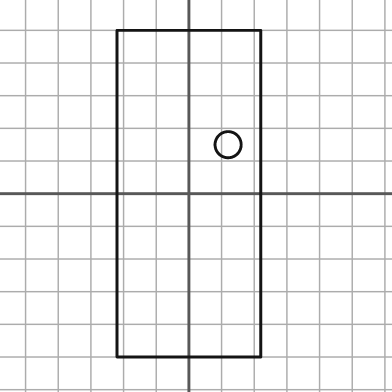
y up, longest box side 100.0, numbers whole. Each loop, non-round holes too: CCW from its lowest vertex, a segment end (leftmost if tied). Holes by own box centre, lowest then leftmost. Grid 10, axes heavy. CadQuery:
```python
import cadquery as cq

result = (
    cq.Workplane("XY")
    .moveTo(-22.0, -50.0)
    .lineTo(22.0, -50.0)
    .lineTo(22.0, 50.0)
    .lineTo(-22.0, 50.0)
    .close()
    .moveTo(12.0, 15.0)
    .circle(4.0)
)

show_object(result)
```